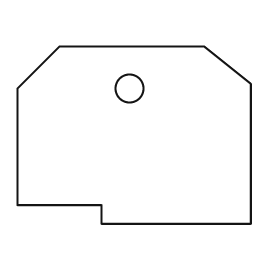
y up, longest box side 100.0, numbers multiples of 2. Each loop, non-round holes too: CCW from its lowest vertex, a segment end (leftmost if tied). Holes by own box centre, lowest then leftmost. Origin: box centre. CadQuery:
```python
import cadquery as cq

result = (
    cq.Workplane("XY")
    .moveTo(-14.0, -38.0)
    .lineTo(50.0, -38.0)
    .lineTo(50.0, 22.0)
    .lineTo(30.0, 38.0)
    .lineTo(-32.0, 38.0)
    .lineTo(-50.0, 20.0)
    .lineTo(-50.0, -30.0)
    .lineTo(-14.0, -30.0)
    .close()
    .moveTo(-2.0, 20.0)
    .circle(6.0)
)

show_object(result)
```